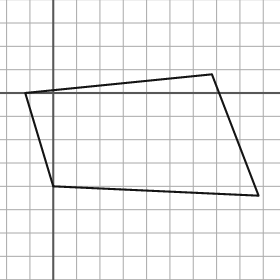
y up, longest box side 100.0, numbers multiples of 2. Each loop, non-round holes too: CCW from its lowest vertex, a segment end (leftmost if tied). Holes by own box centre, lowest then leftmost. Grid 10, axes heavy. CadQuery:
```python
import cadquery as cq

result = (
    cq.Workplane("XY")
    .moveTo(88.0, -44.0)
    .lineTo(68.0, 8.0)
    .lineTo(-12.0, 0.0)
    .lineTo(0.0, -40.0)
    .close()
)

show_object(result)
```